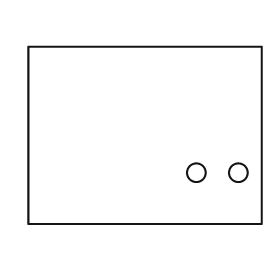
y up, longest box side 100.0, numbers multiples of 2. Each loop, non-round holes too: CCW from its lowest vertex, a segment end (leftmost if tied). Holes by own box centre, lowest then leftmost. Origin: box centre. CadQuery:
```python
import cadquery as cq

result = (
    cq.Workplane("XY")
    .moveTo(-50.0, -38.0)
    .lineTo(50.0, -38.0)
    .lineTo(50.0, 38.0)
    .lineTo(-50.0, 38.0)
    .close()
    .moveTo(22.0, -16.0)
    .circle(4.0)
    .moveTo(40.0, -16.0)
    .circle(4.0)
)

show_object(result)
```